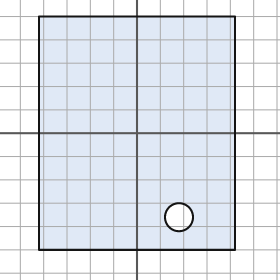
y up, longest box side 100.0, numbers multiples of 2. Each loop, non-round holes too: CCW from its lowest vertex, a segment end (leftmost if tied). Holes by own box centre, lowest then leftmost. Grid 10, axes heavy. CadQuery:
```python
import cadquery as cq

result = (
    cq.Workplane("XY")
    .moveTo(-42.0, -50.0)
    .lineTo(42.0, -50.0)
    .lineTo(42.0, 50.0)
    .lineTo(-42.0, 50.0)
    .close()
    .moveTo(18.0, -36.0)
    .circle(6.0)
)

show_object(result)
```